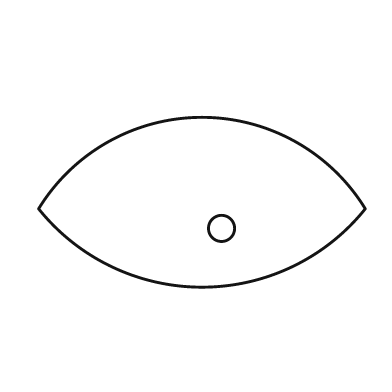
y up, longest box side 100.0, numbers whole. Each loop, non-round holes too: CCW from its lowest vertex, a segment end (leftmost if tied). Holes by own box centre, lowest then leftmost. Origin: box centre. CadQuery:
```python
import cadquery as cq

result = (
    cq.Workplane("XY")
    .moveTo(-50.0, -2.0)
    .threePointArc((0.0, -26.0), (50.0, -2.0))
    .threePointArc((0.0, 26.0), (-50.0, -2.0))
    .close()
    .moveTo(6.0, -8.0)
    .circle(4.0)
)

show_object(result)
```